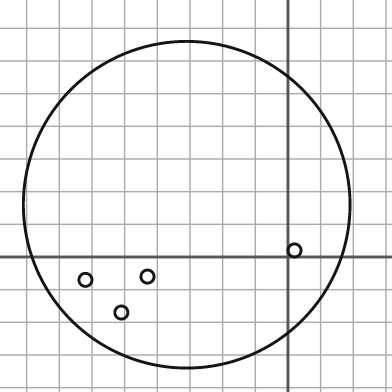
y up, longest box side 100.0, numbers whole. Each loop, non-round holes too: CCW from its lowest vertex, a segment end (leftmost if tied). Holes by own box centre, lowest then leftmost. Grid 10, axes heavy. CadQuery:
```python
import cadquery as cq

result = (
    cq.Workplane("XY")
    .moveTo(-31.0, 16.0)
    .circle(50.0)
    .moveTo(-51.0, -17.0)
    .circle(2.0)
    .moveTo(-62.0, -7.0)
    .circle(2.0)
    .moveTo(-43.0, -6.0)
    .circle(2.0)
    .moveTo(2.0, 2.0)
    .circle(2.0)
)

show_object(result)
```